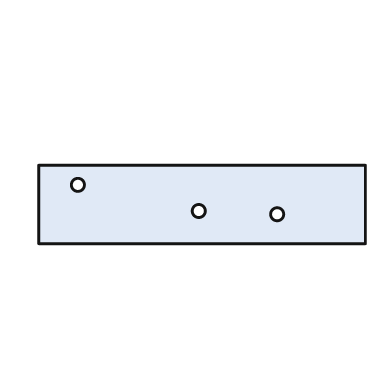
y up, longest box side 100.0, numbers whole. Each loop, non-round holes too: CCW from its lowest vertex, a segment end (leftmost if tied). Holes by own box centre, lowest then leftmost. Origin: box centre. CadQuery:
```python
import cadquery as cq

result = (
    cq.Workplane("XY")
    .moveTo(-50.0, -12.0)
    .lineTo(50.0, -12.0)
    .lineTo(50.0, 12.0)
    .lineTo(-50.0, 12.0)
    .close()
    .moveTo(23.0, -3.0)
    .circle(2.0)
    .moveTo(-1.0, -2.0)
    .circle(2.0)
    .moveTo(-38.0, 6.0)
    .circle(2.0)
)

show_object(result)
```